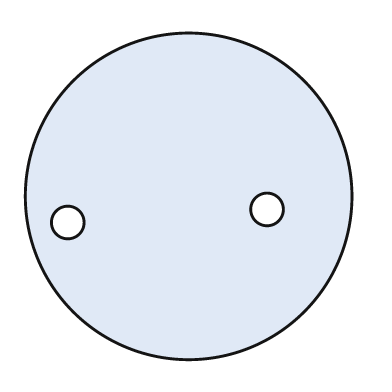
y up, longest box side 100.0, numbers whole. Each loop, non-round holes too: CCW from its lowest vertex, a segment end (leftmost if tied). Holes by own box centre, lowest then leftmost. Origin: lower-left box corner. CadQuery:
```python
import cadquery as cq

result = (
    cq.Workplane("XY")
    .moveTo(50.0, 50.0)
    .circle(50.0)
    .moveTo(13.0, 42.0)
    .circle(5.0)
    .moveTo(74.0, 46.0)
    .circle(5.0)
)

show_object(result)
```